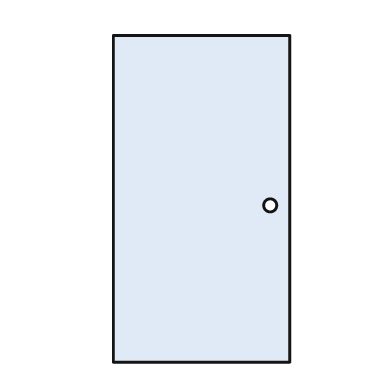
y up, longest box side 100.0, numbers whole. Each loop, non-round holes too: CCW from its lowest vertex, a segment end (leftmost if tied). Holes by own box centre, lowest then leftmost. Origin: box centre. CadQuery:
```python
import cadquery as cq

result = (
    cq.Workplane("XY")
    .moveTo(-27.0, -50.0)
    .lineTo(27.0, -50.0)
    .lineTo(27.0, 50.0)
    .lineTo(-27.0, 50.0)
    .close()
    .moveTo(21.0, -2.0)
    .circle(2.0)
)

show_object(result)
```